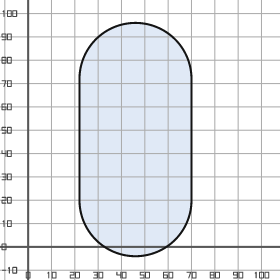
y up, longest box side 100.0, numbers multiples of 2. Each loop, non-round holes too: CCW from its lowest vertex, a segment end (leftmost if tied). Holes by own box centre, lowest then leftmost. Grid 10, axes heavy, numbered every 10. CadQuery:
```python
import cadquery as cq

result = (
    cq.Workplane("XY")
    .moveTo(22.0, 20.0)
    .threePointArc((46.0, -4.0), (70.0, 20.0))
    .lineTo(70.0, 72.0)
    .threePointArc((46.0, 96.0), (22.0, 72.0))
    .close()
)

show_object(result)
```